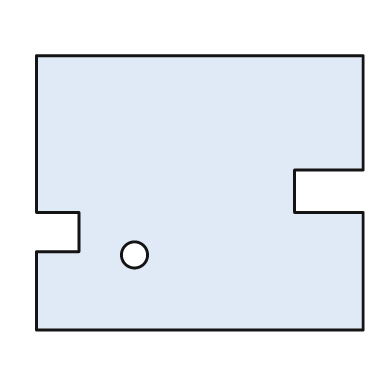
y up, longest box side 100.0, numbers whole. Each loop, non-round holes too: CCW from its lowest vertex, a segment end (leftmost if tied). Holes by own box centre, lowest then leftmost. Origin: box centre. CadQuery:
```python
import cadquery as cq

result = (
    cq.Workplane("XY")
    .moveTo(-50.0, -42.0)
    .lineTo(50.0, -42.0)
    .lineTo(50.0, -6.0)
    .lineTo(29.0, -6.0)
    .lineTo(29.0, 7.0)
    .lineTo(50.0, 7.0)
    .lineTo(50.0, 42.0)
    .lineTo(-50.0, 42.0)
    .lineTo(-50.0, -6.0)
    .lineTo(-37.0, -6.0)
    .lineTo(-37.0, -18.0)
    .lineTo(-50.0, -18.0)
    .close()
    .moveTo(-20.0, -19.0)
    .circle(4.0)
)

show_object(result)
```